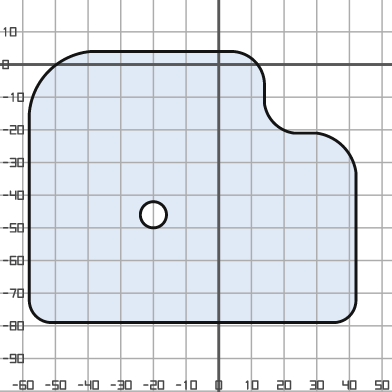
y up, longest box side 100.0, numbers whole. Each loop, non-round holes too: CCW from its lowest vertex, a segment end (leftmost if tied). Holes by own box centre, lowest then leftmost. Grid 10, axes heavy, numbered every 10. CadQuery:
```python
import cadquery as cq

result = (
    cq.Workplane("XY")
    .moveTo(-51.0, -79.0)
    .lineTo(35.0, -79.0)
    .threePointArc((40.0, -77.0), (42.0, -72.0))
    .lineTo(42.0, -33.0)
    .threePointArc((38.0, -25.0), (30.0, -21.0))
    .lineTo(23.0, -21.0)
    .threePointArc((17.0, -18.0), (14.0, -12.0))
    .lineTo(14.0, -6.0)
    .threePointArc((11.0, 1.0), (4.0, 4.0))
    .lineTo(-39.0, 4.0)
    .threePointArc((-52.0, -2.0), (-58.0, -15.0))
    .lineTo(-58.0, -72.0)
    .threePointArc((-56.0, -77.0), (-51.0, -79.0))
    .close()
    .moveTo(-20.0, -46.0)
    .circle(4.0)
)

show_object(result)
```